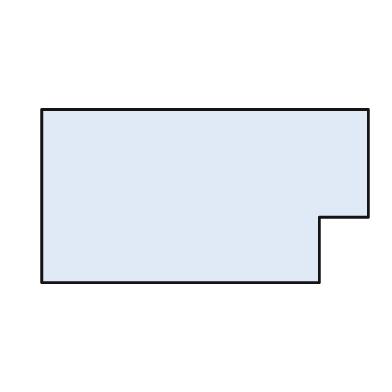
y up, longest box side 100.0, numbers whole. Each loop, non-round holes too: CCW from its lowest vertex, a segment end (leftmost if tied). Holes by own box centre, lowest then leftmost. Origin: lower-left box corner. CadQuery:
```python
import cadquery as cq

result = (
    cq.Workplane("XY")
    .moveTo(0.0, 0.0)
    .lineTo(85.0, 0.0)
    .lineTo(85.0, 20.0)
    .lineTo(100.0, 20.0)
    .lineTo(100.0, 53.0)
    .lineTo(0.0, 53.0)
    .close()
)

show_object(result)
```